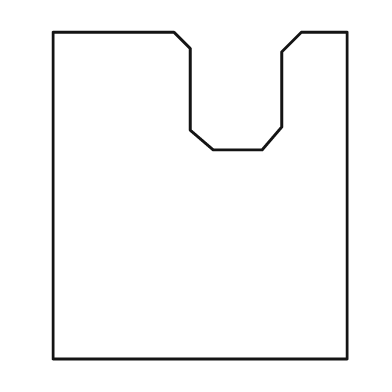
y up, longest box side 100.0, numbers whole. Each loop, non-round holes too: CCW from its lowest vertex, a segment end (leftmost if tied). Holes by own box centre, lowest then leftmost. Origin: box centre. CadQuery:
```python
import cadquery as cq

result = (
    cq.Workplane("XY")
    .moveTo(-45.0, -50.0)
    .lineTo(45.0, -50.0)
    .lineTo(45.0, 50.0)
    .lineTo(31.0, 50.0)
    .lineTo(25.0, 44.0)
    .lineTo(25.0, 21.0)
    .lineTo(19.0, 14.0)
    .lineTo(4.0, 14.0)
    .lineTo(-3.0, 20.0)
    .lineTo(-3.0, 45.0)
    .lineTo(-8.0, 50.0)
    .lineTo(-45.0, 50.0)
    .close()
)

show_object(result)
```